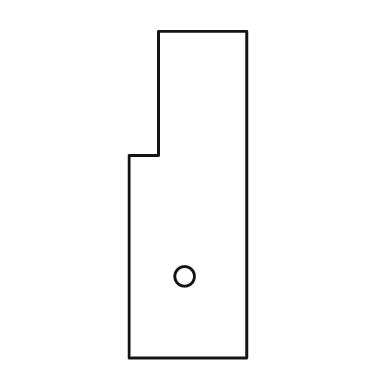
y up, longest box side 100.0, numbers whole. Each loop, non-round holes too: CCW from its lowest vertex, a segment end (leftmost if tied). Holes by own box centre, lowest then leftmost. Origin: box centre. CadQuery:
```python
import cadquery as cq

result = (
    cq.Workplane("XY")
    .moveTo(-18.0, -50.0)
    .lineTo(18.0, -50.0)
    .lineTo(18.0, 50.0)
    .lineTo(-9.0, 50.0)
    .lineTo(-9.0, 12.0)
    .lineTo(-18.0, 12.0)
    .close()
    .moveTo(-1.0, -25.0)
    .circle(3.0)
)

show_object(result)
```